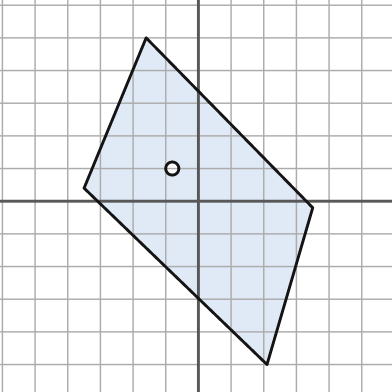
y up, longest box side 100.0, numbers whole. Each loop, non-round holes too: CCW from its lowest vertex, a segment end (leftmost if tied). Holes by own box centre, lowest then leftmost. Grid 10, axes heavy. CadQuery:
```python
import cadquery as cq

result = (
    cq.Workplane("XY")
    .moveTo(21.0, -50.0)
    .lineTo(35.0, -2.0)
    .lineTo(-16.0, 50.0)
    .lineTo(-35.0, 4.0)
    .close()
    .moveTo(-8.0, 10.0)
    .circle(2.0)
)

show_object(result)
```